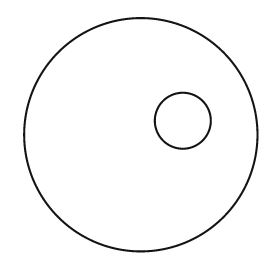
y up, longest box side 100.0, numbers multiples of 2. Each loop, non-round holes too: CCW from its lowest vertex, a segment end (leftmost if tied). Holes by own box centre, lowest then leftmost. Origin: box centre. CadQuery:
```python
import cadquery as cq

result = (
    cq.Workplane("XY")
    .moveTo(0.0, 0.0)
    .circle(50.0)
    .moveTo(18.0, 6.0)
    .circle(12.0)
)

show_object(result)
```